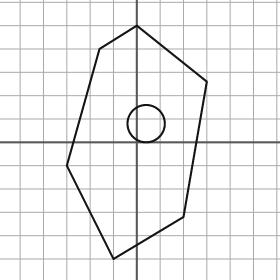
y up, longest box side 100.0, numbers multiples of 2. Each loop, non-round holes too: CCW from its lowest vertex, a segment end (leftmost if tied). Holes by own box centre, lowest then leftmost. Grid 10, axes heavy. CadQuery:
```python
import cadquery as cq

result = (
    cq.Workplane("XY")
    .moveTo(-10.0, -50.0)
    .lineTo(20.0, -32.0)
    .lineTo(30.0, 26.0)
    .lineTo(0.0, 50.0)
    .lineTo(-16.0, 40.0)
    .lineTo(-30.0, -10.0)
    .close()
    .moveTo(4.0, 8.0)
    .circle(8.0)
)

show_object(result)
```